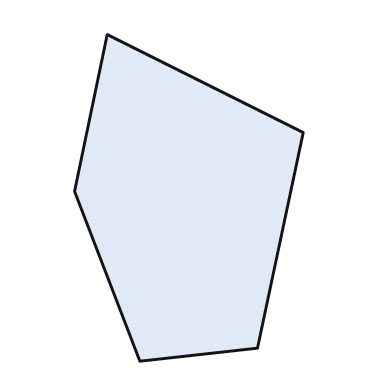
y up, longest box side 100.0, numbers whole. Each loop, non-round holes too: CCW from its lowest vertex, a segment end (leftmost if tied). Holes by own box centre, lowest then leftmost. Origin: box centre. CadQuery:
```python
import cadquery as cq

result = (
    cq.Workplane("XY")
    .moveTo(-15.0, -50.0)
    .lineTo(21.0, -46.0)
    .lineTo(35.0, 20.0)
    .lineTo(-25.0, 50.0)
    .lineTo(-35.0, 2.0)
    .close()
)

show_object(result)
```